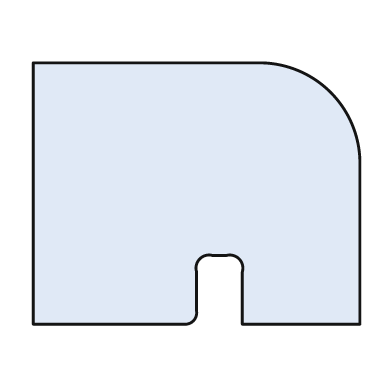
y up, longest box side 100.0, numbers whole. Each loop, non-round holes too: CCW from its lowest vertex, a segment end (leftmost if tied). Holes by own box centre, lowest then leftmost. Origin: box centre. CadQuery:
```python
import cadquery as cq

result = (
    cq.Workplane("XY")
    .moveTo(-50.0, -40.0)
    .lineTo(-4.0, -40.0)
    .threePointArc((-1.0, -39.0), (0.0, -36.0))
    .lineTo(0.0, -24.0)
    .threePointArc((1.0, -20.0), (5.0, -19.0))
    .lineTo(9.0, -19.0)
    .threePointArc((13.0, -20.0), (14.0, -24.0))
    .lineTo(14.0, -40.0)
    .lineTo(50.0, -40.0)
    .lineTo(50.0, 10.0)
    .threePointArc((41.0, 31.0), (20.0, 40.0))
    .lineTo(-50.0, 40.0)
    .close()
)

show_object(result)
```